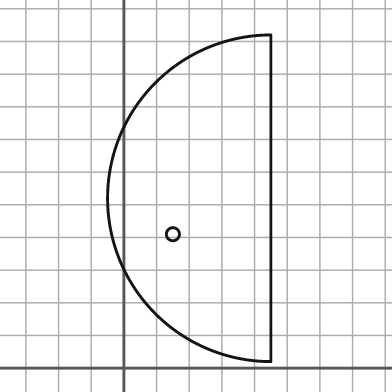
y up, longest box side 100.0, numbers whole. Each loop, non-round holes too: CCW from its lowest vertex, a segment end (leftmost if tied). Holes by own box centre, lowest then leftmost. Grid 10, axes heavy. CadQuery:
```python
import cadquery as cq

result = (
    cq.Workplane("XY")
    .moveTo(45.0, 2.0)
    .lineTo(45.0, 102.0)
    .threePointArc((-5.0, 52.0), (45.0, 2.0))
    .close()
    .moveTo(15.0, 41.0)
    .circle(2.0)
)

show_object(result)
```